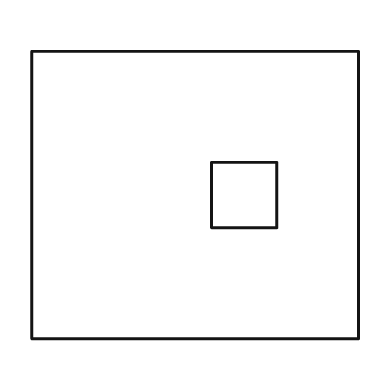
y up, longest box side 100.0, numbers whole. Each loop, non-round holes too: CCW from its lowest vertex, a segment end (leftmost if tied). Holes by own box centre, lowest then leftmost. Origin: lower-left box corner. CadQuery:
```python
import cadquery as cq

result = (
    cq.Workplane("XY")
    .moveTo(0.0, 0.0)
    .lineTo(100.0, 0.0)
    .lineTo(100.0, 88.0)
    .lineTo(0.0, 88.0)
    .close()
    .moveTo(55.0, 34.0)
    .lineTo(75.0, 34.0)
    .lineTo(75.0, 54.0)
    .lineTo(55.0, 54.0)
    .close()
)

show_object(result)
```